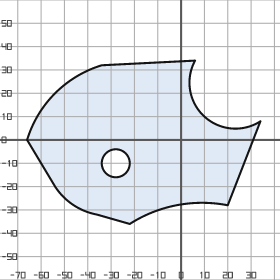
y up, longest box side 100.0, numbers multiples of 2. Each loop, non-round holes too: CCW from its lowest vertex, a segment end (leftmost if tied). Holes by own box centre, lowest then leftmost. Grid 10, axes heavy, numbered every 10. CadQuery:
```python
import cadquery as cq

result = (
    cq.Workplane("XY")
    .moveTo(-22.0, -36.0)
    .threePointArc((-2.0, -28.0), (20.0, -28.0))
    .lineTo(34.0, 8.0)
    .threePointArc((10.0, 10.0), (6.0, 34.0))
    .lineTo(-34.0, 32.0)
    .threePointArc((-54.0, 20.0), (-66.0, 0.0))
    .lineTo(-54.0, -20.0)
    .threePointArc((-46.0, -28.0), (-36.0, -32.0))
    .close()
    .moveTo(-28.0, -10.0)
    .circle(6.0)
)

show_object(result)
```